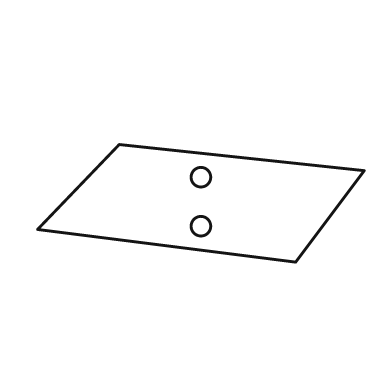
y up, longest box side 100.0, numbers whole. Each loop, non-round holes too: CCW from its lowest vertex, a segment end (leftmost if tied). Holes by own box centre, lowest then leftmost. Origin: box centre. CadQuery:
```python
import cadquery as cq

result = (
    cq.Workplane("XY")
    .moveTo(29.0, -18.0)
    .lineTo(50.0, 10.0)
    .lineTo(-25.0, 18.0)
    .lineTo(-50.0, -8.0)
    .close()
    .moveTo(0.0, -7.0)
    .circle(3.0)
    .moveTo(0.0, 8.0)
    .circle(3.0)
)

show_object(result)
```